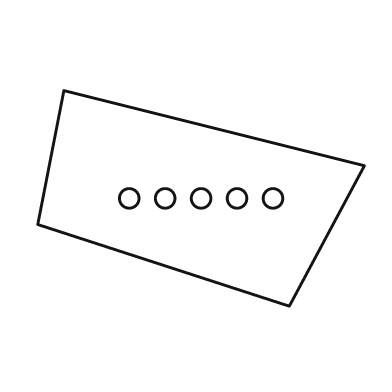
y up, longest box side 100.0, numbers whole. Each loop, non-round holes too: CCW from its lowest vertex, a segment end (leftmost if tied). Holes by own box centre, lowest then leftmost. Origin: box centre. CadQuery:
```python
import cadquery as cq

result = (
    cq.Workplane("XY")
    .moveTo(27.0, -33.0)
    .lineTo(50.0, 10.0)
    .lineTo(-42.0, 33.0)
    .lineTo(-50.0, -8.0)
    .close()
    .moveTo(-22.0, 0.0)
    .circle(3.0)
    .moveTo(-11.0, 0.0)
    .circle(3.0)
    .moveTo(0.0, 0.0)
    .circle(3.0)
    .moveTo(11.0, 0.0)
    .circle(3.0)
    .moveTo(22.0, 0.0)
    .circle(3.0)
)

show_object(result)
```